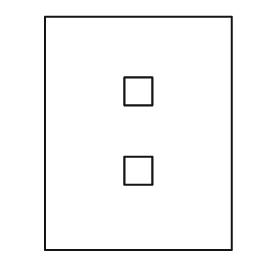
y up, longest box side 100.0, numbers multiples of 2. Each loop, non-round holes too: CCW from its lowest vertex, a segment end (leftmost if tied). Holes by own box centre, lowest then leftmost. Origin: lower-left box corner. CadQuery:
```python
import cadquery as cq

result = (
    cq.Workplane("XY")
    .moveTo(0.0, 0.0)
    .lineTo(80.0, 0.0)
    .lineTo(80.0, 100.0)
    .lineTo(0.0, 100.0)
    .close()
    .moveTo(34.0, 28.0)
    .lineTo(46.0, 28.0)
    .lineTo(46.0, 40.0)
    .lineTo(34.0, 40.0)
    .close()
    .moveTo(34.0, 62.0)
    .lineTo(46.0, 62.0)
    .lineTo(46.0, 74.0)
    .lineTo(34.0, 74.0)
    .close()
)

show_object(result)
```